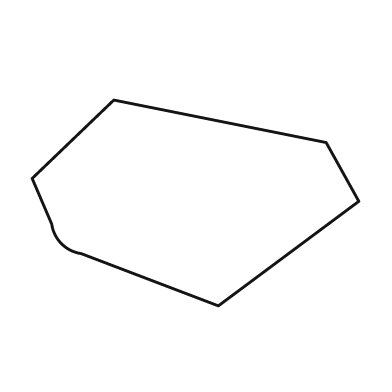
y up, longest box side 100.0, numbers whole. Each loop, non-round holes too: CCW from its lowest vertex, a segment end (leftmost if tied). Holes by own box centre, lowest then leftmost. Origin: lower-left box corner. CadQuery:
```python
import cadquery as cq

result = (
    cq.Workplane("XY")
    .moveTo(57.0, 0.0)
    .lineTo(100.0, 32.0)
    .lineTo(90.0, 50.0)
    .lineTo(25.0, 63.0)
    .lineTo(0.0, 39.0)
    .lineTo(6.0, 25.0)
    .threePointArc((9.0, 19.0), (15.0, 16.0))
    .close()
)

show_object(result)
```